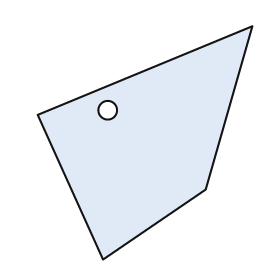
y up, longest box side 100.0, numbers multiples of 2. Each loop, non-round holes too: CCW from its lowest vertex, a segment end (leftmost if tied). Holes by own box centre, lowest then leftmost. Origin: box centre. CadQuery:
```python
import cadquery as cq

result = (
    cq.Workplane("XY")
    .moveTo(-18.0, -50.0)
    .lineTo(26.0, -20.0)
    .lineTo(46.0, 50.0)
    .lineTo(-46.0, 12.0)
    .close()
    .moveTo(-16.0, 14.0)
    .circle(4.0)
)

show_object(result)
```